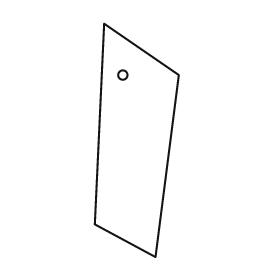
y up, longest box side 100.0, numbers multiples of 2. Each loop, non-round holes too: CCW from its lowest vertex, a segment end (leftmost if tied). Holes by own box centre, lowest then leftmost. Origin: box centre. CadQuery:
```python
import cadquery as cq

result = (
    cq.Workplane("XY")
    .moveTo(8.0, -50.0)
    .lineTo(18.0, 28.0)
    .lineTo(-14.0, 50.0)
    .lineTo(-18.0, -36.0)
    .close()
    .moveTo(-6.0, 28.0)
    .circle(2.0)
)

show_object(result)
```